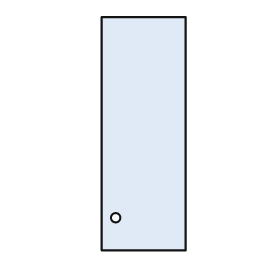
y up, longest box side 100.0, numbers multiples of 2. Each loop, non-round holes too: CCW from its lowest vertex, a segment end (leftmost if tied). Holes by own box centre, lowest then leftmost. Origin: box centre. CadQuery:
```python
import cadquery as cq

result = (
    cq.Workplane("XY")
    .moveTo(-18.0, -50.0)
    .lineTo(18.0, -50.0)
    .lineTo(18.0, 50.0)
    .lineTo(-18.0, 50.0)
    .close()
    .moveTo(-12.0, -36.0)
    .circle(2.0)
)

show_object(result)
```